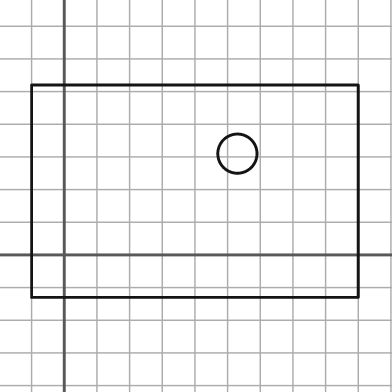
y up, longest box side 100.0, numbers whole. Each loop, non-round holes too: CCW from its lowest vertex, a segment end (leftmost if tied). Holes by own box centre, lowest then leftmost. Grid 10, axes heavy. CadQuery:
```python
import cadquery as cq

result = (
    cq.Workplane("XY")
    .moveTo(-10.0, -13.0)
    .lineTo(90.0, -13.0)
    .lineTo(90.0, 52.0)
    .lineTo(-10.0, 52.0)
    .close()
    .moveTo(53.0, 31.0)
    .circle(6.0)
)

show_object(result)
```